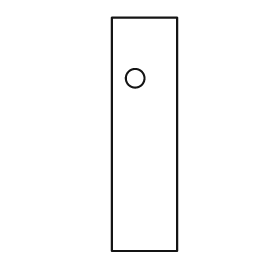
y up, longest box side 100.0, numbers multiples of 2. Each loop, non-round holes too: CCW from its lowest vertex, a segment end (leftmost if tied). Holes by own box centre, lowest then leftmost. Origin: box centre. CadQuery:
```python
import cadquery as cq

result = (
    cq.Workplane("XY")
    .moveTo(-14.0, -50.0)
    .lineTo(14.0, -50.0)
    .lineTo(14.0, 50.0)
    .lineTo(-14.0, 50.0)
    .close()
    .moveTo(-4.0, 24.0)
    .circle(4.0)
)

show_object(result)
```